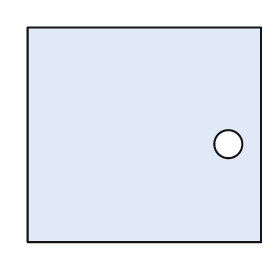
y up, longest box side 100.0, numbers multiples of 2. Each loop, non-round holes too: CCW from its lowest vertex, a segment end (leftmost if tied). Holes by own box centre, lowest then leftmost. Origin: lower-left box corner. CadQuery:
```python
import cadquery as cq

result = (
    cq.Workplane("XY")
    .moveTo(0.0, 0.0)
    .lineTo(100.0, 0.0)
    .lineTo(100.0, 92.0)
    .lineTo(0.0, 92.0)
    .close()
    .moveTo(86.0, 42.0)
    .circle(6.0)
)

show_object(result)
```